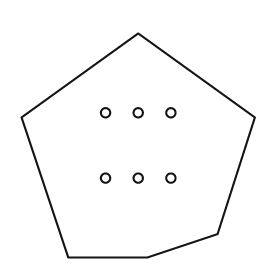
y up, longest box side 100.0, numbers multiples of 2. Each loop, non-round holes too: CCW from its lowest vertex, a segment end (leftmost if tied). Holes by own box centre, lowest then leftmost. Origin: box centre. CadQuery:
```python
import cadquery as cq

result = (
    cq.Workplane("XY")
    .moveTo(-30.0, -48.0)
    .lineTo(4.0, -48.0)
    .lineTo(34.0, -38.0)
    .lineTo(50.0, 12.0)
    .lineTo(0.0, 48.0)
    .lineTo(-50.0, 12.0)
    .close()
    .moveTo(-14.0, -14.0)
    .circle(2.0)
    .moveTo(0.0, -14.0)
    .circle(2.0)
    .moveTo(14.0, -14.0)
    .circle(2.0)
    .moveTo(-14.0, 14.0)
    .circle(2.0)
    .moveTo(0.0, 14.0)
    .circle(2.0)
    .moveTo(14.0, 14.0)
    .circle(2.0)
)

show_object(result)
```